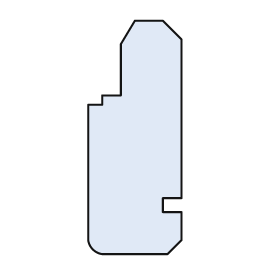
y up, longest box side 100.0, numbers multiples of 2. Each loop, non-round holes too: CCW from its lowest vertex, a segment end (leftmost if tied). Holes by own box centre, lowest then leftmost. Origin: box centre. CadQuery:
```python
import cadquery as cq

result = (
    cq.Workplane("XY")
    .moveTo(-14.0, -50.0)
    .lineTo(14.0, -50.0)
    .lineTo(20.0, -44.0)
    .lineTo(20.0, -32.0)
    .lineTo(12.0, -32.0)
    .lineTo(12.0, -26.0)
    .lineTo(20.0, -26.0)
    .lineTo(20.0, 42.0)
    .lineTo(12.0, 50.0)
    .lineTo(0.0, 50.0)
    .lineTo(-6.0, 40.0)
    .lineTo(-6.0, 18.0)
    .lineTo(-14.0, 18.0)
    .lineTo(-14.0, 14.0)
    .lineTo(-20.0, 14.0)
    .lineTo(-20.0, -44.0)
    .threePointArc((-18.0, -48.0), (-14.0, -50.0))
    .close()
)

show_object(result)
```